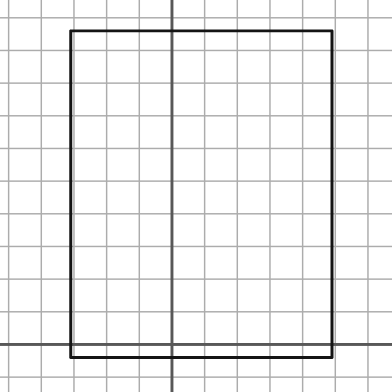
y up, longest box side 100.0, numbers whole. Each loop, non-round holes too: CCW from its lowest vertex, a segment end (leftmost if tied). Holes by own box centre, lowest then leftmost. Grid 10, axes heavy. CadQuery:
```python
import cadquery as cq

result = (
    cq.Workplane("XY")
    .moveTo(-31.0, -4.0)
    .lineTo(49.0, -4.0)
    .lineTo(49.0, 96.0)
    .lineTo(-31.0, 96.0)
    .close()
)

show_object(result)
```